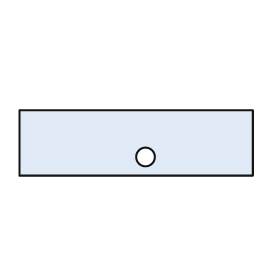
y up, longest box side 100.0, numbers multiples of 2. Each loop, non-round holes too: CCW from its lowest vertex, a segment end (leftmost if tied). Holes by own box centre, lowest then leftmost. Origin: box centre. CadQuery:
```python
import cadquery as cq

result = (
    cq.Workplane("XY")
    .moveTo(-50.0, -14.0)
    .lineTo(50.0, -14.0)
    .lineTo(50.0, 14.0)
    .lineTo(-50.0, 14.0)
    .close()
    .moveTo(4.0, -6.0)
    .circle(4.0)
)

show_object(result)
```